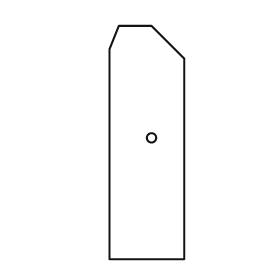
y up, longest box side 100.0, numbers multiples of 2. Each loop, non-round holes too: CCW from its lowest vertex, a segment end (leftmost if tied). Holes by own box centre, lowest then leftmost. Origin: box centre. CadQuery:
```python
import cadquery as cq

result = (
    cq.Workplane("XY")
    .moveTo(-16.0, -50.0)
    .lineTo(16.0, -50.0)
    .lineTo(16.0, 36.0)
    .lineTo(2.0, 50.0)
    .lineTo(-12.0, 50.0)
    .lineTo(-16.0, 40.0)
    .close()
    .moveTo(2.0, 2.0)
    .circle(2.0)
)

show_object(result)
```